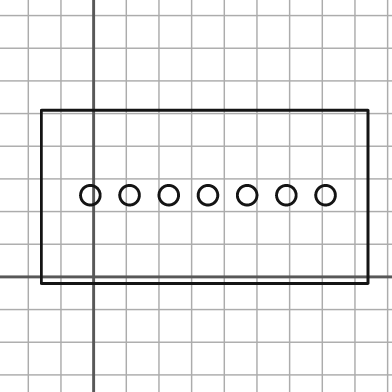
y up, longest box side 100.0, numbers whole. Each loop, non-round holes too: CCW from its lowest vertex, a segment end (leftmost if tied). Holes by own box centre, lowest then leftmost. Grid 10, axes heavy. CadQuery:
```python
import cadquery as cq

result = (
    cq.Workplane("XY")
    .moveTo(-16.0, -2.0)
    .lineTo(84.0, -2.0)
    .lineTo(84.0, 51.0)
    .lineTo(-16.0, 51.0)
    .close()
    .moveTo(-1.0, 25.0)
    .circle(3.0)
    .moveTo(11.0, 25.0)
    .circle(3.0)
    .moveTo(23.0, 25.0)
    .circle(3.0)
    .moveTo(35.0, 25.0)
    .circle(3.0)
    .moveTo(47.0, 25.0)
    .circle(3.0)
    .moveTo(59.0, 25.0)
    .circle(3.0)
    .moveTo(71.0, 25.0)
    .circle(3.0)
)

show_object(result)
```